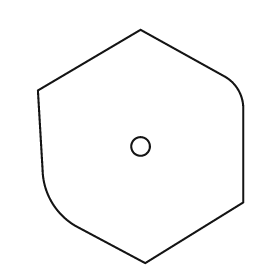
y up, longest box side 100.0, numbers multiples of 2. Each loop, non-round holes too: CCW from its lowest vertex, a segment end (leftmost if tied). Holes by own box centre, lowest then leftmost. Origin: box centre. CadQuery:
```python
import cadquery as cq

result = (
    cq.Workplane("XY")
    .moveTo(2.0, -50.0)
    .lineTo(44.0, -24.0)
    .lineTo(44.0, 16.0)
    .threePointArc((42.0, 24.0), (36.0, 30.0))
    .lineTo(0.0, 50.0)
    .lineTo(-44.0, 24.0)
    .lineTo(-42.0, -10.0)
    .threePointArc((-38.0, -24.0), (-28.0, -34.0))
    .close()
    .moveTo(0.0, 0.0)
    .circle(4.0)
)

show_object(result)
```